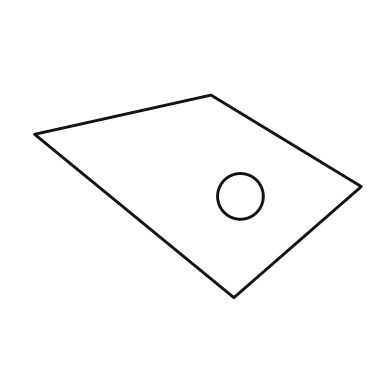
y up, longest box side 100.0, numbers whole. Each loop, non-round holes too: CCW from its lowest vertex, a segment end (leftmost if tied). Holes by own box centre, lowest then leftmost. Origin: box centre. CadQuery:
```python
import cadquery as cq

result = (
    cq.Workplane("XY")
    .moveTo(11.0, -31.0)
    .lineTo(50.0, 3.0)
    .lineTo(4.0, 31.0)
    .lineTo(-50.0, 19.0)
    .close()
    .moveTo(13.0, 0.0)
    .circle(7.0)
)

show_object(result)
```